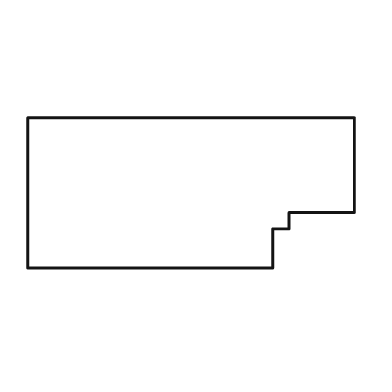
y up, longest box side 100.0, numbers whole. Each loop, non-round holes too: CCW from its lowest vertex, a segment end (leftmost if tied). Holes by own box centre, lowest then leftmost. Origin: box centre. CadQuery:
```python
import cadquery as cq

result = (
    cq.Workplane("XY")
    .moveTo(-50.0, -23.0)
    .lineTo(25.0, -23.0)
    .lineTo(25.0, -11.0)
    .lineTo(30.0, -11.0)
    .lineTo(30.0, -6.0)
    .lineTo(50.0, -6.0)
    .lineTo(50.0, 23.0)
    .lineTo(-50.0, 23.0)
    .close()
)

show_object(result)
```